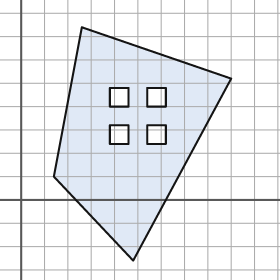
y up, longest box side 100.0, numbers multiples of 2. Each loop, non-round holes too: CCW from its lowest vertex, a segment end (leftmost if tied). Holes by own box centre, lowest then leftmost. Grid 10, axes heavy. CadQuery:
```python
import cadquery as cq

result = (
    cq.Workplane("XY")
    .moveTo(48.0, -26.0)
    .lineTo(90.0, 52.0)
    .lineTo(26.0, 74.0)
    .lineTo(14.0, 10.0)
    .close()
    .moveTo(38.0, 24.0)
    .lineTo(46.0, 24.0)
    .lineTo(46.0, 32.0)
    .lineTo(38.0, 32.0)
    .close()
    .moveTo(54.0, 24.0)
    .lineTo(62.0, 24.0)
    .lineTo(62.0, 32.0)
    .lineTo(54.0, 32.0)
    .close()
    .moveTo(38.0, 40.0)
    .lineTo(46.0, 40.0)
    .lineTo(46.0, 48.0)
    .lineTo(38.0, 48.0)
    .close()
    .moveTo(54.0, 40.0)
    .lineTo(62.0, 40.0)
    .lineTo(62.0, 48.0)
    .lineTo(54.0, 48.0)
    .close()
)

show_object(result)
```